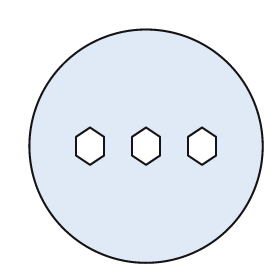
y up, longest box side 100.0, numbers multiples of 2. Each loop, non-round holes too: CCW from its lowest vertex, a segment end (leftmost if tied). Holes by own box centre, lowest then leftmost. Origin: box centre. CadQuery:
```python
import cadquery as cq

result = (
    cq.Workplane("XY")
    .moveTo(0.0, 0.0)
    .circle(50.0)
    .moveTo(-24.0, -8.0)
    .lineTo(-18.0, -4.0)
    .lineTo(-18.0, 4.0)
    .lineTo(-24.0, 8.0)
    .lineTo(-30.0, 4.0)
    .lineTo(-30.0, -4.0)
    .close()
    .moveTo(0.0, -8.0)
    .lineTo(6.0, -4.0)
    .lineTo(6.0, 4.0)
    .lineTo(0.0, 8.0)
    .lineTo(-6.0, 4.0)
    .lineTo(-6.0, -4.0)
    .close()
    .moveTo(24.0, -8.0)
    .lineTo(30.0, -4.0)
    .lineTo(30.0, 4.0)
    .lineTo(24.0, 8.0)
    .lineTo(18.0, 4.0)
    .lineTo(18.0, -4.0)
    .close()
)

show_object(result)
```